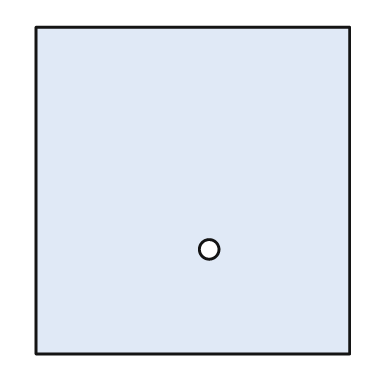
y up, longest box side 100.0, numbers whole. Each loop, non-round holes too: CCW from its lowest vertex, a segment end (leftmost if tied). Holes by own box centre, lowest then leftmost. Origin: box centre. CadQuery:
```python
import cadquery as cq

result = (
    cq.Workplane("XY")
    .moveTo(-48.0, -50.0)
    .lineTo(48.0, -50.0)
    .lineTo(48.0, 50.0)
    .lineTo(-48.0, 50.0)
    .close()
    .moveTo(5.0, -18.0)
    .circle(3.0)
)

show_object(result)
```